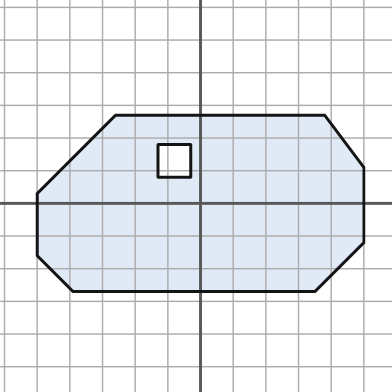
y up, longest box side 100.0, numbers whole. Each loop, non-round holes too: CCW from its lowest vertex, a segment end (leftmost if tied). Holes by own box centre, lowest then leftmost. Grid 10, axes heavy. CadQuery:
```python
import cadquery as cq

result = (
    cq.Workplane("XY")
    .moveTo(-39.0, -27.0)
    .lineTo(35.0, -27.0)
    .lineTo(50.0, -12.0)
    .lineTo(50.0, 11.0)
    .lineTo(38.0, 27.0)
    .lineTo(-26.0, 27.0)
    .lineTo(-50.0, 3.0)
    .lineTo(-50.0, -16.0)
    .close()
    .moveTo(-13.0, 8.0)
    .lineTo(-3.0, 8.0)
    .lineTo(-3.0, 18.0)
    .lineTo(-13.0, 18.0)
    .close()
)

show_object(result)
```